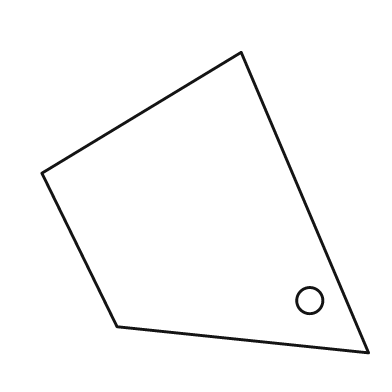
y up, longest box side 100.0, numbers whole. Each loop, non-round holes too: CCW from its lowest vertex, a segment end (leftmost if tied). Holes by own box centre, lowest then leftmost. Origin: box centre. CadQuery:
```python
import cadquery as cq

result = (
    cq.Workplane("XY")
    .moveTo(50.0, -46.0)
    .lineTo(11.0, 46.0)
    .lineTo(-50.0, 9.0)
    .lineTo(-27.0, -38.0)
    .close()
    .moveTo(32.0, -30.0)
    .circle(4.0)
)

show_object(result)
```